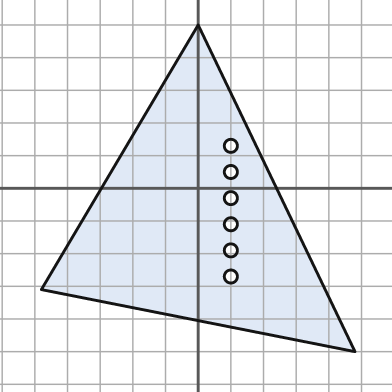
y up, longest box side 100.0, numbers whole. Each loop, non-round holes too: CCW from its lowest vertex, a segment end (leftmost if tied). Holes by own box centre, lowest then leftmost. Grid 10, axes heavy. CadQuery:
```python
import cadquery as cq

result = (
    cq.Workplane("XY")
    .moveTo(48.0, -50.0)
    .lineTo(0.0, 50.0)
    .lineTo(-48.0, -31.0)
    .close()
    .moveTo(10.0, -27.0)
    .circle(2.0)
    .moveTo(10.0, -19.0)
    .circle(2.0)
    .moveTo(10.0, -11.0)
    .circle(2.0)
    .moveTo(10.0, -3.0)
    .circle(2.0)
    .moveTo(10.0, 5.0)
    .circle(2.0)
    .moveTo(10.0, 13.0)
    .circle(2.0)
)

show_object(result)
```